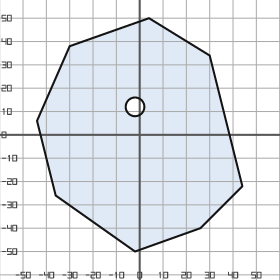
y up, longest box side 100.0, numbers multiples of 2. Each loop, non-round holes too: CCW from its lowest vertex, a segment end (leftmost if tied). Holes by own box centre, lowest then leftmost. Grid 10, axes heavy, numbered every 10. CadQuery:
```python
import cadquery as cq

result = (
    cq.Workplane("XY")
    .moveTo(-2.0, -50.0)
    .lineTo(26.0, -40.0)
    .lineTo(44.0, -22.0)
    .lineTo(30.0, 34.0)
    .lineTo(4.0, 50.0)
    .lineTo(-30.0, 38.0)
    .lineTo(-44.0, 6.0)
    .lineTo(-36.0, -26.0)
    .close()
    .moveTo(-2.0, 12.0)
    .circle(4.0)
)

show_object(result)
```